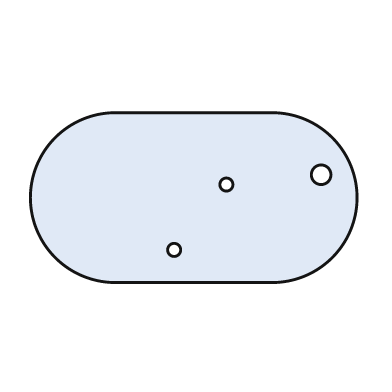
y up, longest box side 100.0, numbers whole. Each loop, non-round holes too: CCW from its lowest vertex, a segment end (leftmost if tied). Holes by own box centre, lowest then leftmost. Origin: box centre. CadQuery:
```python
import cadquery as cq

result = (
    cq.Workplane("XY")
    .moveTo(-24.0, -26.0)
    .lineTo(24.0, -26.0)
    .threePointArc((50.0, 0.0), (24.0, 26.0))
    .lineTo(-24.0, 26.0)
    .threePointArc((-50.0, 0.0), (-24.0, -26.0))
    .close()
    .moveTo(-6.0, -16.0)
    .circle(2.0)
    .moveTo(10.0, 4.0)
    .circle(2.0)
    .moveTo(39.0, 7.0)
    .circle(3.0)
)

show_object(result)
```